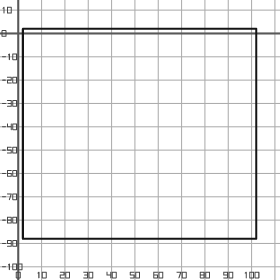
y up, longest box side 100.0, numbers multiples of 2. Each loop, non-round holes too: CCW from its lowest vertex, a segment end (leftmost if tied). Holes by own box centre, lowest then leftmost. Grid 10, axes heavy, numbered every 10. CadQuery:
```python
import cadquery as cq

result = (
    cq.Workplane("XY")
    .moveTo(2.0, -88.0)
    .lineTo(102.0, -88.0)
    .lineTo(102.0, 2.0)
    .lineTo(2.0, 2.0)
    .close()
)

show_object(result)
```